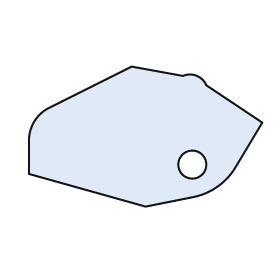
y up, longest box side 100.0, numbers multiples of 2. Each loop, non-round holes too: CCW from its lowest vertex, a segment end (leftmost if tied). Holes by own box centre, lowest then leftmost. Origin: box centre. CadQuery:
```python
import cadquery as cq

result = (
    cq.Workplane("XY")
    .moveTo(0.0, -30.0)
    .lineTo(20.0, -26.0)
    .threePointArc((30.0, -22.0), (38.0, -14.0))
    .lineTo(50.0, 6.0)
    .lineTo(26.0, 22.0)
    .threePointArc((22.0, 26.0), (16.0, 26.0))
    .lineTo(-6.0, 30.0)
    .lineTo(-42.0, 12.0)
    .threePointArc((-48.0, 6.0), (-50.0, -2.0))
    .lineTo(-50.0, -16.0)
    .close()
    .moveTo(20.0, -12.0)
    .circle(6.0)
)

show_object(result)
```